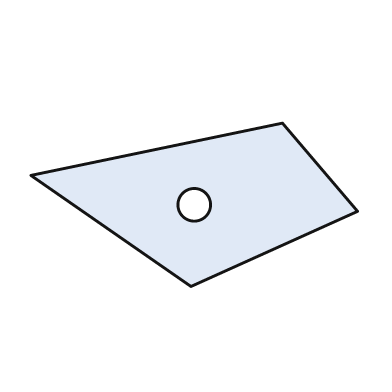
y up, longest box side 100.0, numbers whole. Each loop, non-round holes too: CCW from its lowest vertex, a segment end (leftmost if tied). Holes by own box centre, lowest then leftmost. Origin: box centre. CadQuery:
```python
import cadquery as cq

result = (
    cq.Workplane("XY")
    .moveTo(-1.0, -25.0)
    .lineTo(50.0, -2.0)
    .lineTo(27.0, 25.0)
    .lineTo(-50.0, 9.0)
    .close()
    .moveTo(0.0, 0.0)
    .circle(5.0)
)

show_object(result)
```